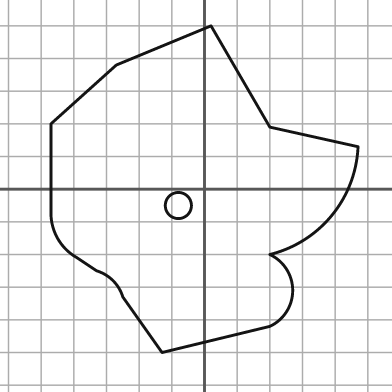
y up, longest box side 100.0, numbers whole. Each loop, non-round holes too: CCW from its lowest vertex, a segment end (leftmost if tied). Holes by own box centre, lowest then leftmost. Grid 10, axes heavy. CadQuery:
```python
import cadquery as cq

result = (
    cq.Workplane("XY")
    .moveTo(-13.0, -50.0)
    .lineTo(20.0, -42.0)
    .threePointArc((27.0, -31.0), (20.0, -20.0))
    .threePointArc((39.0, -8.0), (47.0, 13.0))
    .lineTo(20.0, 19.0)
    .lineTo(2.0, 50.0)
    .lineTo(-27.0, 38.0)
    .lineTo(-47.0, 20.0)
    .lineTo(-47.0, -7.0)
    .threePointArc((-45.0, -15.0), (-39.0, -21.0))
    .lineTo(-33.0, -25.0)
    .threePointArc((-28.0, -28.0), (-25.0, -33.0))
    .close()
    .moveTo(-8.0, -5.0)
    .circle(4.0)
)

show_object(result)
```